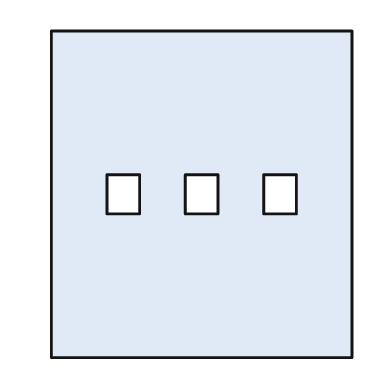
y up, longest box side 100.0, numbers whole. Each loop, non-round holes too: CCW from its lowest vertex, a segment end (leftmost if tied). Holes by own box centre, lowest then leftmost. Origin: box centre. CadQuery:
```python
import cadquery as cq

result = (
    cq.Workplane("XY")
    .moveTo(-46.0, -50.0)
    .lineTo(46.0, -50.0)
    .lineTo(46.0, 50.0)
    .lineTo(-46.0, 50.0)
    .close()
    .moveTo(-29.0, -6.0)
    .lineTo(-19.0, -6.0)
    .lineTo(-19.0, 6.0)
    .lineTo(-29.0, 6.0)
    .close()
    .moveTo(-5.0, -6.0)
    .lineTo(5.0, -6.0)
    .lineTo(5.0, 6.0)
    .lineTo(-5.0, 6.0)
    .close()
    .moveTo(19.0, -6.0)
    .lineTo(29.0, -6.0)
    .lineTo(29.0, 6.0)
    .lineTo(19.0, 6.0)
    .close()
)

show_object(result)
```